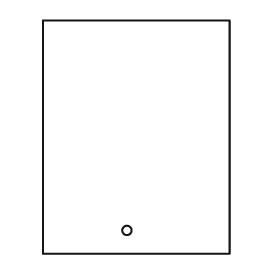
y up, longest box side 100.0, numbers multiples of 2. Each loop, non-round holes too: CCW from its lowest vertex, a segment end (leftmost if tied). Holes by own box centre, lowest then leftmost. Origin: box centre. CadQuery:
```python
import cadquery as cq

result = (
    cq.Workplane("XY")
    .moveTo(-40.0, -50.0)
    .lineTo(40.0, -50.0)
    .lineTo(40.0, 50.0)
    .lineTo(-40.0, 50.0)
    .close()
    .moveTo(-4.0, -40.0)
    .circle(2.0)
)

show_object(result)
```